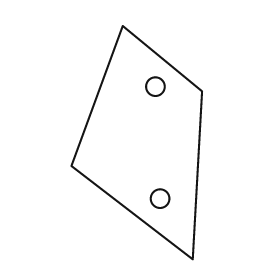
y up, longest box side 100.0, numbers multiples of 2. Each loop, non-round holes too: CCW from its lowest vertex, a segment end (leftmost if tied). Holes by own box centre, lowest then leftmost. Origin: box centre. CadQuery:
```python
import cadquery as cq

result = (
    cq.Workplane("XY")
    .moveTo(24.0, -50.0)
    .lineTo(28.0, 22.0)
    .lineTo(-6.0, 50.0)
    .lineTo(-28.0, -10.0)
    .close()
    .moveTo(10.0, -24.0)
    .circle(4.0)
    .moveTo(8.0, 24.0)
    .circle(4.0)
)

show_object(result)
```